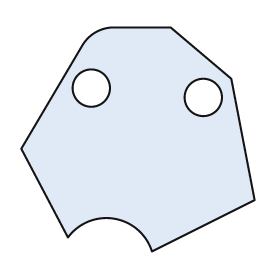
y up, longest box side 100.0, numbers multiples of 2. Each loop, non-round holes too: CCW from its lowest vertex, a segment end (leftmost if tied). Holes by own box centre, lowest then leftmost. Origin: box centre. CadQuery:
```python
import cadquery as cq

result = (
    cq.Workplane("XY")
    .moveTo(6.0, -48.0)
    .lineTo(50.0, -26.0)
    .lineTo(40.0, 26.0)
    .lineTo(14.0, 48.0)
    .lineTo(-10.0, 48.0)
    .threePointArc((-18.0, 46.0), (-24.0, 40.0))
    .lineTo(-50.0, -4.0)
    .lineTo(-30.0, -42.0)
    .threePointArc((-10.0, -34.0), (6.0, -48.0))
    .close()
    .moveTo(28.0, 18.0)
    .circle(8.0)
    .moveTo(-20.0, 22.0)
    .circle(8.0)
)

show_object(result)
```